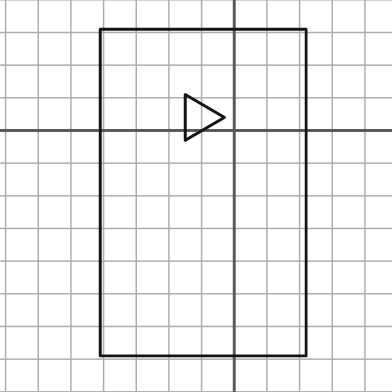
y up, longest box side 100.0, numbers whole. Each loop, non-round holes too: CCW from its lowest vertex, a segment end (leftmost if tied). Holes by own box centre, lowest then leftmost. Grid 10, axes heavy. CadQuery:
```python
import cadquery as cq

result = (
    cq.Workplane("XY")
    .moveTo(-41.0, -69.0)
    .lineTo(22.0, -69.0)
    .lineTo(22.0, 31.0)
    .lineTo(-41.0, 31.0)
    .close()
    .moveTo(-15.0, -3.0)
    .lineTo(-3.0, 4.0)
    .lineTo(-15.0, 11.0)
    .close()
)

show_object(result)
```